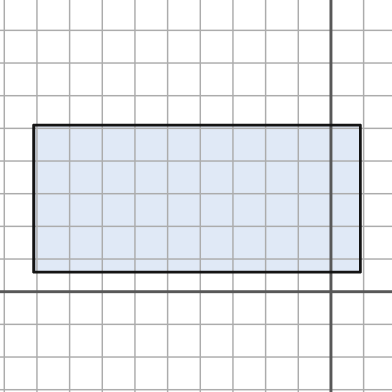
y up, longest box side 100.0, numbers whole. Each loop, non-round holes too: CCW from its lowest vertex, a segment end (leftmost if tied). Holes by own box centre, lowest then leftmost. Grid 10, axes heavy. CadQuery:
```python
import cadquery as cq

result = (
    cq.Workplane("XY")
    .moveTo(-91.0, 6.0)
    .lineTo(9.0, 6.0)
    .lineTo(9.0, 51.0)
    .lineTo(-91.0, 51.0)
    .close()
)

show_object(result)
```